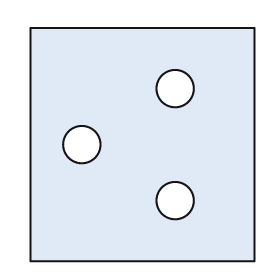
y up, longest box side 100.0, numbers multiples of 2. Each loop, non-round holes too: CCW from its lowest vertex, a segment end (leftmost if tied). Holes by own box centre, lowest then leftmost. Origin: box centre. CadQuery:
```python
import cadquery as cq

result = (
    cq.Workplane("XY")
    .moveTo(-48.0, -50.0)
    .lineTo(48.0, -50.0)
    .lineTo(48.0, 50.0)
    .lineTo(-48.0, 50.0)
    .close()
    .moveTo(14.0, -24.0)
    .circle(8.0)
    .moveTo(-26.0, 0.0)
    .circle(8.0)
    .moveTo(14.0, 24.0)
    .circle(8.0)
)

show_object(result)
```